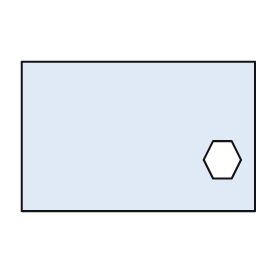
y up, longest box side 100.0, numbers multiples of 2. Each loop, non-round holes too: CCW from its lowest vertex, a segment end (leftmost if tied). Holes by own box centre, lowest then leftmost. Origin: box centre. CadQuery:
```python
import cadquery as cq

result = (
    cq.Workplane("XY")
    .moveTo(-50.0, -32.0)
    .lineTo(50.0, -32.0)
    .lineTo(50.0, 32.0)
    .lineTo(-50.0, 32.0)
    .close()
    .moveTo(32.0, -18.0)
    .lineTo(40.0, -18.0)
    .lineTo(44.0, -10.0)
    .lineTo(40.0, -2.0)
    .lineTo(32.0, -2.0)
    .lineTo(28.0, -10.0)
    .close()
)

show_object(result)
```